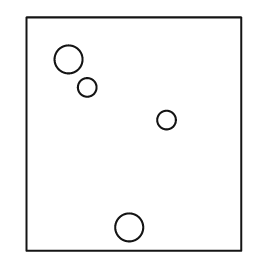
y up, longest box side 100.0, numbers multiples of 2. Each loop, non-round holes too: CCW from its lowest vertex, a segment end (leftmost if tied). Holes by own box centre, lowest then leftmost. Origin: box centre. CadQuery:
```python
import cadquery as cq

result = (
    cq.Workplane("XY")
    .moveTo(-46.0, -50.0)
    .lineTo(46.0, -50.0)
    .lineTo(46.0, 50.0)
    .lineTo(-46.0, 50.0)
    .close()
    .moveTo(-2.0, -40.0)
    .circle(6.0)
    .moveTo(14.0, 6.0)
    .circle(4.0)
    .moveTo(-20.0, 20.0)
    .circle(4.0)
    .moveTo(-28.0, 32.0)
    .circle(6.0)
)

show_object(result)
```